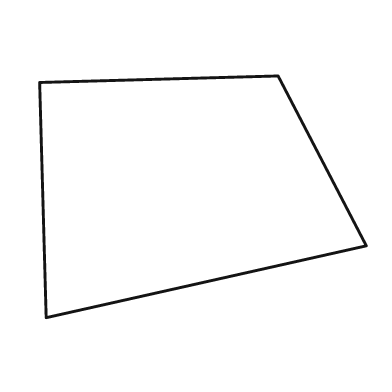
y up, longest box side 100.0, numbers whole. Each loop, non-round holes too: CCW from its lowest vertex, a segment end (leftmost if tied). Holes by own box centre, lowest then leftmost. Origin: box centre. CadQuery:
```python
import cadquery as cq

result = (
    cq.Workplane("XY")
    .moveTo(-48.0, -37.0)
    .lineTo(50.0, -15.0)
    .lineTo(23.0, 37.0)
    .lineTo(-50.0, 35.0)
    .close()
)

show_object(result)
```